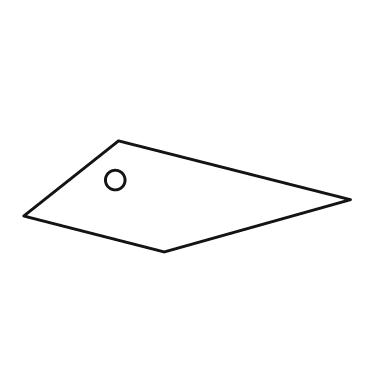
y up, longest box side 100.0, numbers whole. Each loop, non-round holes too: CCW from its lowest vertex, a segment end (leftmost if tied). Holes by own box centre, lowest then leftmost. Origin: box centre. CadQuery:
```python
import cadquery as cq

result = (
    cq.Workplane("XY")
    .moveTo(-7.0, -17.0)
    .lineTo(50.0, -1.0)
    .lineTo(-21.0, 17.0)
    .lineTo(-50.0, -6.0)
    .close()
    .moveTo(-22.0, 5.0)
    .circle(3.0)
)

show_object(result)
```